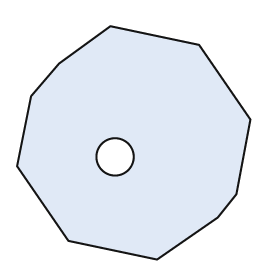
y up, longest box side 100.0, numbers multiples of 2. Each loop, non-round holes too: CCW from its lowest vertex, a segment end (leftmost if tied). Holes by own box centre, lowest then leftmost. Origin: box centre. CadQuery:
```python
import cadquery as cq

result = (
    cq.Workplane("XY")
    .moveTo(10.0, -50.0)
    .lineTo(36.0, -32.0)
    .lineTo(44.0, -22.0)
    .lineTo(50.0, 10.0)
    .lineTo(28.0, 42.0)
    .lineTo(-10.0, 50.0)
    .lineTo(-32.0, 34.0)
    .lineTo(-44.0, 20.0)
    .lineTo(-50.0, -10.0)
    .lineTo(-28.0, -42.0)
    .close()
    .moveTo(-8.0, -6.0)
    .circle(8.0)
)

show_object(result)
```